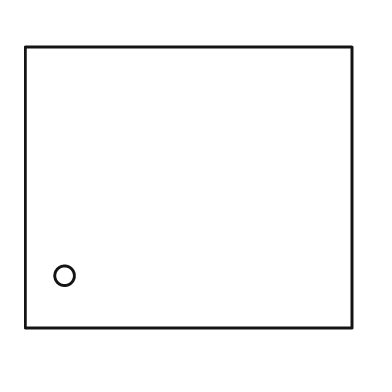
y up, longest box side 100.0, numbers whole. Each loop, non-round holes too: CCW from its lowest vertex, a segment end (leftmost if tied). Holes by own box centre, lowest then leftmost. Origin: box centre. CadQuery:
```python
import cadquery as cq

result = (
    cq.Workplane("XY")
    .moveTo(-50.0, -43.0)
    .lineTo(50.0, -43.0)
    .lineTo(50.0, 43.0)
    .lineTo(-50.0, 43.0)
    .close()
    .moveTo(-38.0, -27.0)
    .circle(3.0)
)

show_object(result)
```